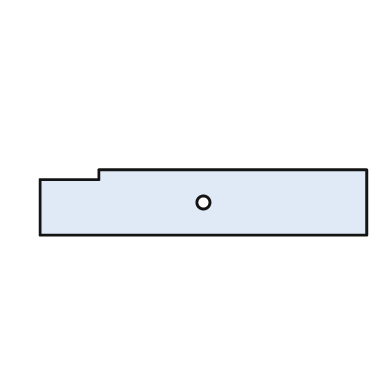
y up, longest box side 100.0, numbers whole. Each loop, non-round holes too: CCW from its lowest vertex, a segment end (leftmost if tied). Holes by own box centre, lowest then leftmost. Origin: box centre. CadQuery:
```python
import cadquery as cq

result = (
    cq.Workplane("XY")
    .moveTo(-50.0, -10.0)
    .lineTo(50.0, -10.0)
    .lineTo(50.0, 10.0)
    .lineTo(-32.0, 10.0)
    .lineTo(-32.0, 7.0)
    .lineTo(-50.0, 7.0)
    .close()
    .moveTo(0.0, 0.0)
    .circle(2.0)
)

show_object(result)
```